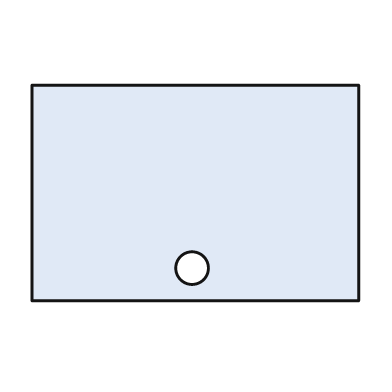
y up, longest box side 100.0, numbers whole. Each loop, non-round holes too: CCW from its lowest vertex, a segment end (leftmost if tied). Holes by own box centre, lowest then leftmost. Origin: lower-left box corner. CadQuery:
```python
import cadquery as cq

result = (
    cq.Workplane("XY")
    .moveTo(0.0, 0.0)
    .lineTo(100.0, 0.0)
    .lineTo(100.0, 66.0)
    .lineTo(0.0, 66.0)
    .close()
    .moveTo(49.0, 10.0)
    .circle(5.0)
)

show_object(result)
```